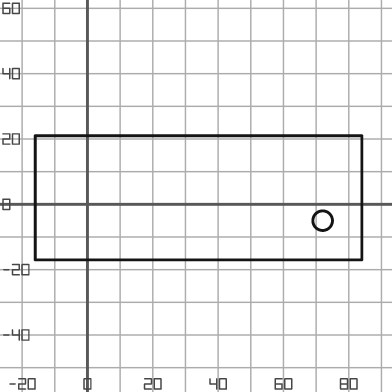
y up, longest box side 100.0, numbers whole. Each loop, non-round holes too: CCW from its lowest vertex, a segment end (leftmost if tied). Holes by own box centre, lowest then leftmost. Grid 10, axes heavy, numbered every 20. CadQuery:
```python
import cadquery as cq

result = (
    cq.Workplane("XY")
    .moveTo(-16.0, -17.0)
    .lineTo(84.0, -17.0)
    .lineTo(84.0, 21.0)
    .lineTo(-16.0, 21.0)
    .close()
    .moveTo(72.0, -5.0)
    .circle(3.0)
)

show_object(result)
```